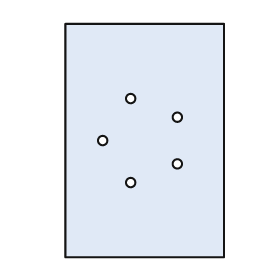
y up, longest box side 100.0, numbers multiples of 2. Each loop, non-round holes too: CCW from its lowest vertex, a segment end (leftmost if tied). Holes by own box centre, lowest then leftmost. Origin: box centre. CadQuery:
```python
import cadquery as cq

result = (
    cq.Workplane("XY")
    .moveTo(-34.0, -50.0)
    .lineTo(34.0, -50.0)
    .lineTo(34.0, 50.0)
    .lineTo(-34.0, 50.0)
    .close()
    .moveTo(-6.0, -18.0)
    .circle(2.0)
    .moveTo(14.0, -10.0)
    .circle(2.0)
    .moveTo(-18.0, 0.0)
    .circle(2.0)
    .moveTo(14.0, 10.0)
    .circle(2.0)
    .moveTo(-6.0, 18.0)
    .circle(2.0)
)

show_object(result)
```